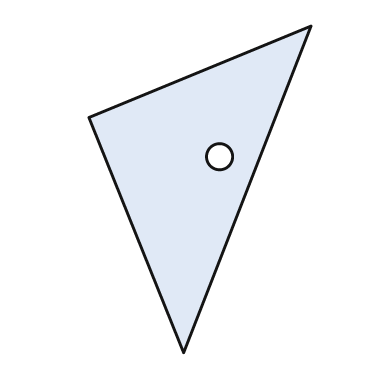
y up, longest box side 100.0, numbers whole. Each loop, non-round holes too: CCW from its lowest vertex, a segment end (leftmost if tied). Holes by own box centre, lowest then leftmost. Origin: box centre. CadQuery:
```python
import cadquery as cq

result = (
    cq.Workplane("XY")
    .moveTo(-5.0, -50.0)
    .lineTo(34.0, 50.0)
    .lineTo(-34.0, 22.0)
    .close()
    .moveTo(6.0, 10.0)
    .circle(4.0)
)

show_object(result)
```